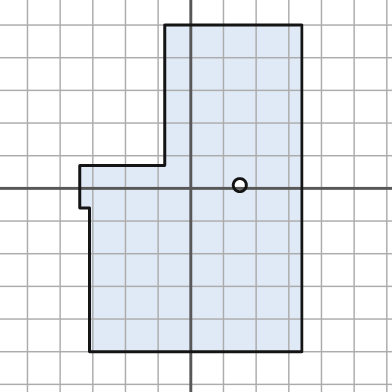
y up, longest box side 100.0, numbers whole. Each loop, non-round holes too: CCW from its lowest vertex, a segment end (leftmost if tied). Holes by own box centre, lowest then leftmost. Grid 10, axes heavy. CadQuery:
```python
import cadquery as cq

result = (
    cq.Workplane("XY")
    .moveTo(-31.0, -50.0)
    .lineTo(34.0, -50.0)
    .lineTo(34.0, 50.0)
    .lineTo(-8.0, 50.0)
    .lineTo(-8.0, 7.0)
    .lineTo(-34.0, 7.0)
    .lineTo(-34.0, -6.0)
    .lineTo(-31.0, -6.0)
    .close()
    .moveTo(15.0, 1.0)
    .circle(2.0)
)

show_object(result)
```